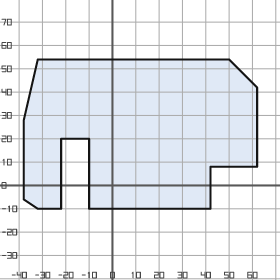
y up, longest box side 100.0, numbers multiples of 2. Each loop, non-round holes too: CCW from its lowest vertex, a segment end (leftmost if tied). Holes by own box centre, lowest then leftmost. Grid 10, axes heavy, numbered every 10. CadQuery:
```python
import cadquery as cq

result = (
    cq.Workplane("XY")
    .moveTo(-32.0, -10.0)
    .lineTo(-22.0, -10.0)
    .lineTo(-22.0, 20.0)
    .lineTo(-10.0, 20.0)
    .lineTo(-10.0, -10.0)
    .lineTo(42.0, -10.0)
    .lineTo(42.0, 8.0)
    .lineTo(62.0, 8.0)
    .lineTo(62.0, 42.0)
    .lineTo(50.0, 54.0)
    .lineTo(-32.0, 54.0)
    .lineTo(-38.0, 28.0)
    .lineTo(-38.0, -6.0)
    .close()
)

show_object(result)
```